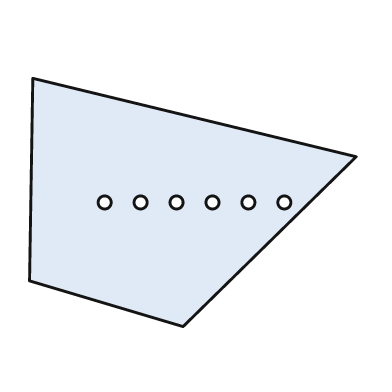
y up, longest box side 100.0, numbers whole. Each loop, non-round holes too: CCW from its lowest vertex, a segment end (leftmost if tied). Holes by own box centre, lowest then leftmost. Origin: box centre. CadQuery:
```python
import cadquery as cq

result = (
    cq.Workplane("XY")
    .moveTo(-3.0, -38.0)
    .lineTo(50.0, 14.0)
    .lineTo(-49.0, 38.0)
    .lineTo(-50.0, -24.0)
    .close()
    .moveTo(-27.0, 0.0)
    .circle(2.0)
    .moveTo(-16.0, 0.0)
    .circle(2.0)
    .moveTo(-5.0, 0.0)
    .circle(2.0)
    .moveTo(6.0, 0.0)
    .circle(2.0)
    .moveTo(17.0, 0.0)
    .circle(2.0)
    .moveTo(28.0, 0.0)
    .circle(2.0)
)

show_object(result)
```